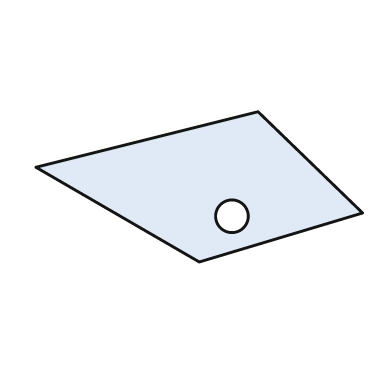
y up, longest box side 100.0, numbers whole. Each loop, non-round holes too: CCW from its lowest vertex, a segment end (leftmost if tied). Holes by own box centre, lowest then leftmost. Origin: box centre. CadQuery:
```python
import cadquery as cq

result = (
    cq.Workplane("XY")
    .moveTo(0.0, -23.0)
    .lineTo(50.0, -8.0)
    .lineTo(18.0, 23.0)
    .lineTo(-50.0, 6.0)
    .close()
    .moveTo(10.0, -9.0)
    .circle(5.0)
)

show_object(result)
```